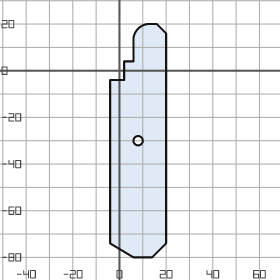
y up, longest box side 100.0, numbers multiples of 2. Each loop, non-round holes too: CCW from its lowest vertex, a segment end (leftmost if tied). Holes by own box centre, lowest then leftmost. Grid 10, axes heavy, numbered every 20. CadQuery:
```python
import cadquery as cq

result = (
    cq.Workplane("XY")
    .moveTo(6.0, -80.0)
    .lineTo(14.0, -80.0)
    .lineTo(20.0, -74.0)
    .lineTo(20.0, 16.0)
    .lineTo(16.0, 20.0)
    .lineTo(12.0, 20.0)
    .threePointArc((8.0, 18.0), (6.0, 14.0))
    .lineTo(6.0, 4.0)
    .lineTo(2.0, 4.0)
    .lineTo(2.0, -4.0)
    .lineTo(-4.0, -4.0)
    .lineTo(-4.0, -74.0)
    .close()
    .moveTo(8.0, -30.0)
    .circle(2.0)
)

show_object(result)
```